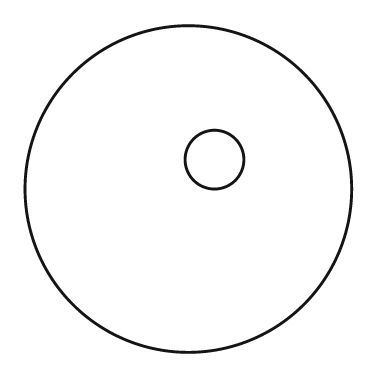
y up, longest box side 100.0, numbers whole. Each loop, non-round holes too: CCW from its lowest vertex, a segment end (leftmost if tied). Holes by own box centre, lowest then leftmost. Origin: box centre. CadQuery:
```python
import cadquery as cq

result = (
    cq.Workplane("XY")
    .moveTo(0.0, 0.0)
    .circle(50.0)
    .moveTo(8.0, 9.0)
    .circle(9.0)
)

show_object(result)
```